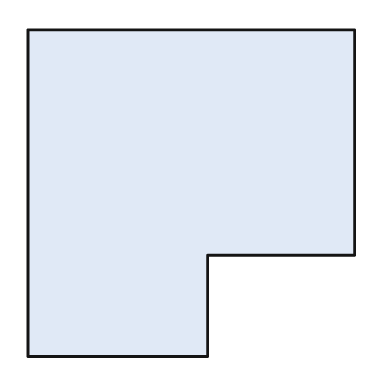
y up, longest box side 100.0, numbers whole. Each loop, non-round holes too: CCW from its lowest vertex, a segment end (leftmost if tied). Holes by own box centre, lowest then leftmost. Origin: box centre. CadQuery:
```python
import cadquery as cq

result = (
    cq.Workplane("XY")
    .moveTo(-50.0, -50.0)
    .lineTo(5.0, -50.0)
    .lineTo(5.0, -19.0)
    .lineTo(50.0, -19.0)
    .lineTo(50.0, 50.0)
    .lineTo(-50.0, 50.0)
    .close()
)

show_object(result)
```